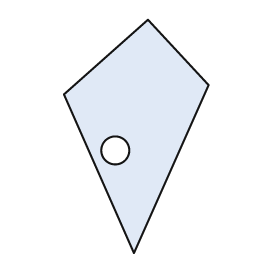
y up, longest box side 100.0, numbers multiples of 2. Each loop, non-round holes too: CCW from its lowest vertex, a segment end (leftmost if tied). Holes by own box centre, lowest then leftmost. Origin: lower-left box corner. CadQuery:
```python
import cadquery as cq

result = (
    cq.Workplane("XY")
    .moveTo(30.0, 0.0)
    .lineTo(62.0, 72.0)
    .lineTo(36.0, 100.0)
    .lineTo(0.0, 68.0)
    .close()
    .moveTo(22.0, 44.0)
    .circle(6.0)
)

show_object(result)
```